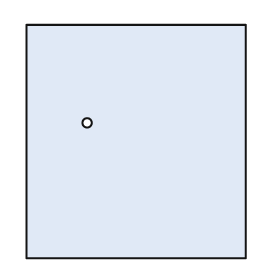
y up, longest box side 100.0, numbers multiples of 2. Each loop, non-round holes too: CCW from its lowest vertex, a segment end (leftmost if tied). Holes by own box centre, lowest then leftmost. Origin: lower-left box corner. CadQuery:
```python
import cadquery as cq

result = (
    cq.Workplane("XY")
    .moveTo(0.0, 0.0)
    .lineTo(94.0, 0.0)
    .lineTo(94.0, 100.0)
    .lineTo(0.0, 100.0)
    .close()
    .moveTo(26.0, 58.0)
    .circle(2.0)
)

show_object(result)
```